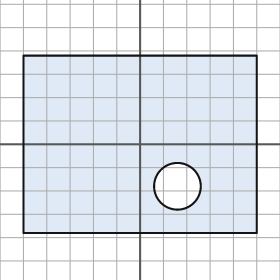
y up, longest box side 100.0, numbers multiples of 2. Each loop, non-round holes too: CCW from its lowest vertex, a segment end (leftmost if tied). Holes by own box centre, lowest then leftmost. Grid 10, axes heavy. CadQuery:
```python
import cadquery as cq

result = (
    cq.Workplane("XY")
    .moveTo(-50.0, -38.0)
    .lineTo(50.0, -38.0)
    .lineTo(50.0, 38.0)
    .lineTo(-50.0, 38.0)
    .close()
    .moveTo(16.0, -18.0)
    .circle(10.0)
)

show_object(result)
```